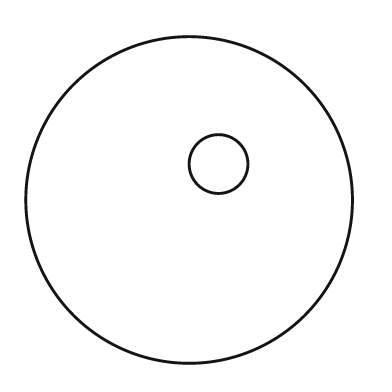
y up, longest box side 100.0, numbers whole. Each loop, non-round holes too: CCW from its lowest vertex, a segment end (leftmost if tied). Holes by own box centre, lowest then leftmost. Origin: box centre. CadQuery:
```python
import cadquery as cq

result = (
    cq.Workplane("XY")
    .moveTo(0.0, 0.0)
    .circle(50.0)
    .moveTo(9.0, 11.0)
    .circle(9.0)
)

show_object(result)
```